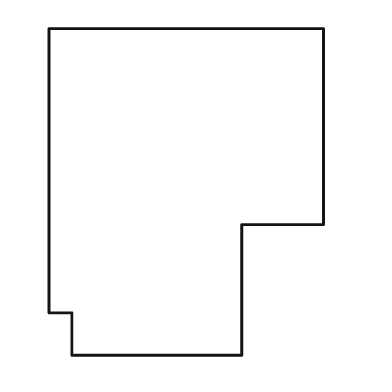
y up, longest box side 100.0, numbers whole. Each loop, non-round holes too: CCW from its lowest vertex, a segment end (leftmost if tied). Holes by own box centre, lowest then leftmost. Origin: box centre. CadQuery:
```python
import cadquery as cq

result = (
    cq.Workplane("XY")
    .moveTo(-35.0, -50.0)
    .lineTo(17.0, -50.0)
    .lineTo(17.0, -10.0)
    .lineTo(42.0, -10.0)
    .lineTo(42.0, 50.0)
    .lineTo(-42.0, 50.0)
    .lineTo(-42.0, -37.0)
    .lineTo(-35.0, -37.0)
    .close()
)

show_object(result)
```